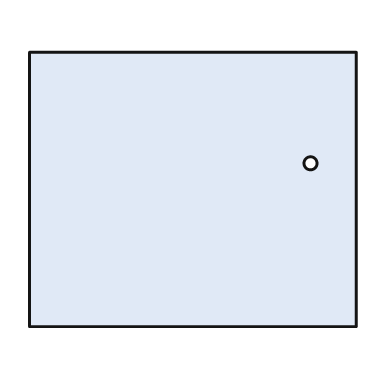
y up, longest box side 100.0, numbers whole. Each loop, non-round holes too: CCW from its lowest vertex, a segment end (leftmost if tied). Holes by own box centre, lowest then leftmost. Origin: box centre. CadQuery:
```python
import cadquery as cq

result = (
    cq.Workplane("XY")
    .moveTo(-50.0, -42.0)
    .lineTo(50.0, -42.0)
    .lineTo(50.0, 42.0)
    .lineTo(-50.0, 42.0)
    .close()
    .moveTo(36.0, 8.0)
    .circle(2.0)
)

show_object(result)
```